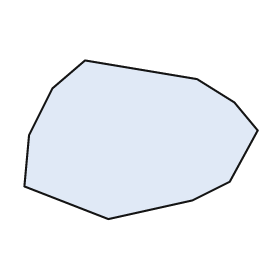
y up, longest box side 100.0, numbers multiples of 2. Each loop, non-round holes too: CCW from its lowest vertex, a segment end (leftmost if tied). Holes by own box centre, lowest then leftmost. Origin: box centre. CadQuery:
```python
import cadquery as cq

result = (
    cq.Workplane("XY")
    .moveTo(-14.0, -34.0)
    .lineTo(22.0, -26.0)
    .lineTo(38.0, -18.0)
    .lineTo(50.0, 4.0)
    .lineTo(40.0, 16.0)
    .lineTo(24.0, 26.0)
    .lineTo(-24.0, 34.0)
    .lineTo(-38.0, 22.0)
    .lineTo(-48.0, 2.0)
    .lineTo(-50.0, -20.0)
    .close()
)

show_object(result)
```